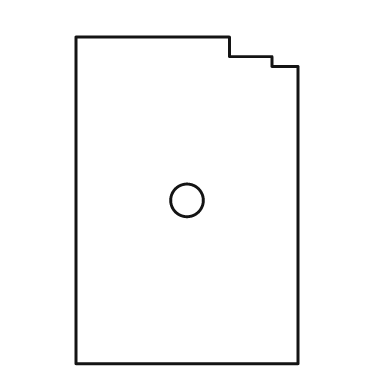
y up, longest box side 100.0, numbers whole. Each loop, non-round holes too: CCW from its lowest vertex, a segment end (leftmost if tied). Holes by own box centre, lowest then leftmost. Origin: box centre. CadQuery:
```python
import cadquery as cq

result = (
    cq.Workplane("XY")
    .moveTo(-34.0, -50.0)
    .lineTo(34.0, -50.0)
    .lineTo(34.0, 41.0)
    .lineTo(26.0, 41.0)
    .lineTo(26.0, 44.0)
    .lineTo(13.0, 44.0)
    .lineTo(13.0, 50.0)
    .lineTo(-34.0, 50.0)
    .close()
    .moveTo(0.0, 0.0)
    .circle(5.0)
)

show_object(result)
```